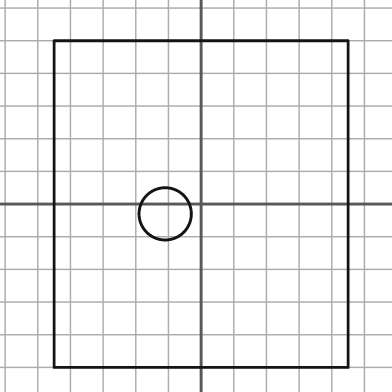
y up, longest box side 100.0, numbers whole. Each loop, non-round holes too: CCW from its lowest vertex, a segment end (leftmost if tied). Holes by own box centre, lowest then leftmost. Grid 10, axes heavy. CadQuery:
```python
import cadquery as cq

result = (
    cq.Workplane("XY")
    .moveTo(-45.0, -50.0)
    .lineTo(45.0, -50.0)
    .lineTo(45.0, 50.0)
    .lineTo(-45.0, 50.0)
    .close()
    .moveTo(-11.0, -3.0)
    .circle(8.0)
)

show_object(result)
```